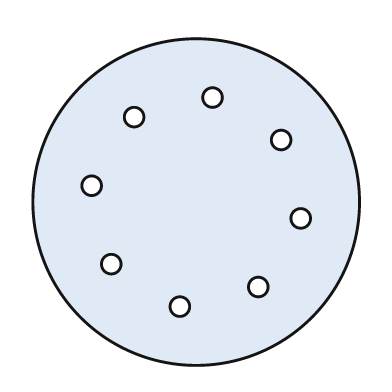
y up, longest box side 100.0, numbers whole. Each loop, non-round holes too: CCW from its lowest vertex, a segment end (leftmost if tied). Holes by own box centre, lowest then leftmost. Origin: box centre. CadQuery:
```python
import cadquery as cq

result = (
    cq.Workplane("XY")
    .moveTo(0.0, 0.0)
    .circle(50.0)
    .moveTo(-5.0, -32.0)
    .circle(3.0)
    .moveTo(19.0, -26.0)
    .circle(3.0)
    .moveTo(-26.0, -19.0)
    .circle(3.0)
    .moveTo(32.0, -5.0)
    .circle(3.0)
    .moveTo(-32.0, 5.0)
    .circle(3.0)
    .moveTo(26.0, 19.0)
    .circle(3.0)
    .moveTo(-19.0, 26.0)
    .circle(3.0)
    .moveTo(5.0, 32.0)
    .circle(3.0)
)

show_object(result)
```